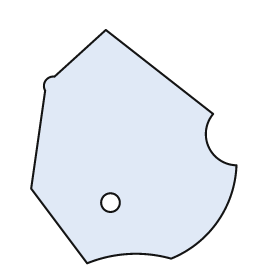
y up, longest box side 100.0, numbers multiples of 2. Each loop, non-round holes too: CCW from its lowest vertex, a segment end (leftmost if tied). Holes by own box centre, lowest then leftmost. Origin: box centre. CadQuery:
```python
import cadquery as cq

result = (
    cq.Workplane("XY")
    .moveTo(-20.0, -50.0)
    .threePointArc((-2.0, -46.0), (16.0, -48.0))
    .threePointArc((36.0, -32.0), (44.0, -8.0))
    .threePointArc((32.0, 0.0), (34.0, 14.0))
    .lineTo(-12.0, 50.0)
    .lineTo(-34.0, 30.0)
    .threePointArc((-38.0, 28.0), (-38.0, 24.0))
    .lineTo(-44.0, -18.0)
    .close()
    .moveTo(-10.0, -24.0)
    .circle(4.0)
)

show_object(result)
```